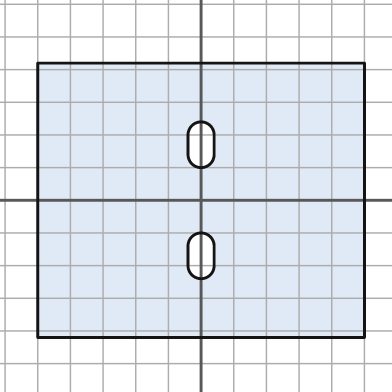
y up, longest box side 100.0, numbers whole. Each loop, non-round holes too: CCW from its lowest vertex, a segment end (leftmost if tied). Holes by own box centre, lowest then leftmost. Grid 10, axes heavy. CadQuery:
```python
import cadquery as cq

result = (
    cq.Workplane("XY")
    .moveTo(-50.0, -42.0)
    .lineTo(50.0, -42.0)
    .lineTo(50.0, 42.0)
    .lineTo(-50.0, 42.0)
    .close()
    .moveTo(-4.0, -20.0)
    .threePointArc((0.0, -24.0), (4.0, -20.0))
    .lineTo(4.0, -14.0)
    .threePointArc((0.0, -10.0), (-4.0, -14.0))
    .close()
    .moveTo(-4.0, 14.0)
    .threePointArc((0.0, 10.0), (4.0, 14.0))
    .lineTo(4.0, 20.0)
    .threePointArc((0.0, 24.0), (-4.0, 20.0))
    .close()
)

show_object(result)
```